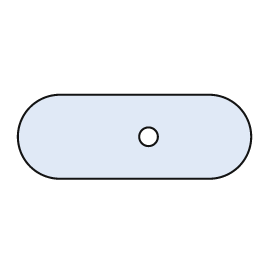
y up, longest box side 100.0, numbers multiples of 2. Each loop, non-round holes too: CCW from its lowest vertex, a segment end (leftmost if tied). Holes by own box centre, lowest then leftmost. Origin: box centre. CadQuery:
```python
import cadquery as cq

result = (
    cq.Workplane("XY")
    .moveTo(-32.0, -18.0)
    .lineTo(32.0, -18.0)
    .threePointArc((50.0, 0.0), (32.0, 18.0))
    .lineTo(-32.0, 18.0)
    .threePointArc((-50.0, 0.0), (-32.0, -18.0))
    .close()
    .moveTo(6.0, 0.0)
    .circle(4.0)
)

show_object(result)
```